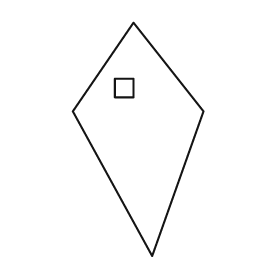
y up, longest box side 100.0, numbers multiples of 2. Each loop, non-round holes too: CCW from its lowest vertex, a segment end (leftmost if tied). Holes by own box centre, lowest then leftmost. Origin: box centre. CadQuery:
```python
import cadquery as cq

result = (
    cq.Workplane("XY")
    .moveTo(6.0, -50.0)
    .lineTo(28.0, 12.0)
    .lineTo(-2.0, 50.0)
    .lineTo(-28.0, 12.0)
    .close()
    .moveTo(-10.0, 18.0)
    .lineTo(-2.0, 18.0)
    .lineTo(-2.0, 26.0)
    .lineTo(-10.0, 26.0)
    .close()
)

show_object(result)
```